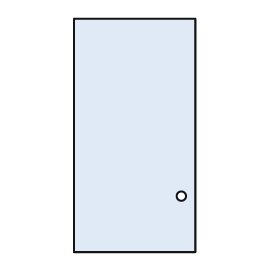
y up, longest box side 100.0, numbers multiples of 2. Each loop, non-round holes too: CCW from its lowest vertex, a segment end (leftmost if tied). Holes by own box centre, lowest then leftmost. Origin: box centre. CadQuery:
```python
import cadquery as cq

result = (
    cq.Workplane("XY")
    .moveTo(-26.0, -50.0)
    .lineTo(26.0, -50.0)
    .lineTo(26.0, 50.0)
    .lineTo(-26.0, 50.0)
    .close()
    .moveTo(20.0, -26.0)
    .circle(2.0)
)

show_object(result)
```